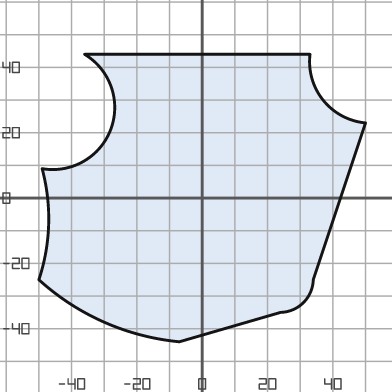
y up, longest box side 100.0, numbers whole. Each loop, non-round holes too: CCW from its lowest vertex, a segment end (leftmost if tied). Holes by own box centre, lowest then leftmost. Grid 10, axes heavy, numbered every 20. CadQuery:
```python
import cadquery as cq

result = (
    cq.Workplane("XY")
    .moveTo(-7.0, -44.0)
    .lineTo(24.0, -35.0)
    .threePointArc((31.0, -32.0), (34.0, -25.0))
    .lineTo(50.0, 23.0)
    .threePointArc((37.0, 30.0), (33.0, 44.0))
    .lineTo(-36.0, 44.0)
    .threePointArc((-28.0, 21.0), (-49.0, 9.0))
    .threePointArc((-47.0, -8.0), (-50.0, -25.0))
    .threePointArc((-30.0, -38.0), (-7.0, -44.0))
    .close()
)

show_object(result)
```